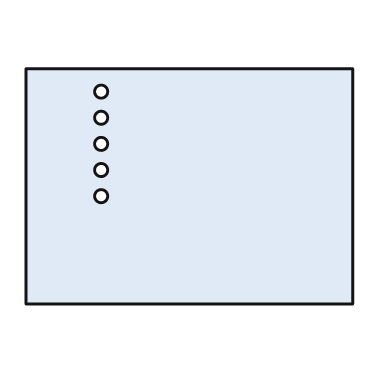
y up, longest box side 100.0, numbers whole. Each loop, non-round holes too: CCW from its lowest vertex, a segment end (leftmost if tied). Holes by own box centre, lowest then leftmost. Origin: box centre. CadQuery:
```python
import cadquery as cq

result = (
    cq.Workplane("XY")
    .moveTo(-50.0, -36.0)
    .lineTo(50.0, -36.0)
    .lineTo(50.0, 36.0)
    .lineTo(-50.0, 36.0)
    .close()
    .moveTo(-27.0, -3.0)
    .circle(2.0)
    .moveTo(-27.0, 5.0)
    .circle(2.0)
    .moveTo(-27.0, 13.0)
    .circle(2.0)
    .moveTo(-27.0, 21.0)
    .circle(2.0)
    .moveTo(-27.0, 29.0)
    .circle(2.0)
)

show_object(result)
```